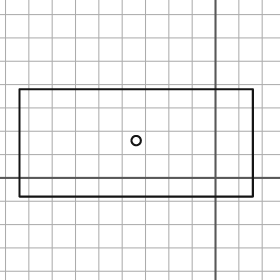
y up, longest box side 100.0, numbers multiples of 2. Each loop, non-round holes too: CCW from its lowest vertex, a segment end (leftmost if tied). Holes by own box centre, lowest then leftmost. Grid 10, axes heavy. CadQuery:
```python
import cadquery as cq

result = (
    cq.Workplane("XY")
    .moveTo(-84.0, -8.0)
    .lineTo(16.0, -8.0)
    .lineTo(16.0, 38.0)
    .lineTo(-84.0, 38.0)
    .close()
    .moveTo(-34.0, 16.0)
    .circle(2.0)
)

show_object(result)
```